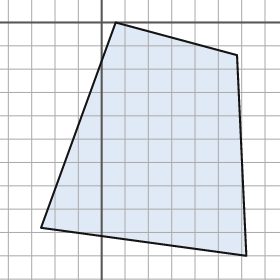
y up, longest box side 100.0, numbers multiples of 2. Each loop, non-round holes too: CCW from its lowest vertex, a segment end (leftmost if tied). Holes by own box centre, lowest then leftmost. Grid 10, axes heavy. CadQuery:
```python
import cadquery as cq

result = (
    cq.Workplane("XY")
    .moveTo(62.0, -100.0)
    .lineTo(58.0, -14.0)
    .lineTo(6.0, 0.0)
    .lineTo(-26.0, -88.0)
    .close()
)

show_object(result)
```